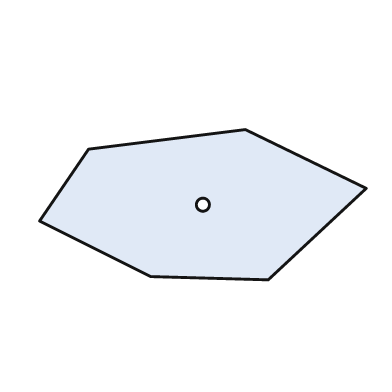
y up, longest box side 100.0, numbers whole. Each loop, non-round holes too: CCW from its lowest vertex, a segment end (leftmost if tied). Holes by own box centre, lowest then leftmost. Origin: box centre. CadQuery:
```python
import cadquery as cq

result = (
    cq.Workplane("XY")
    .moveTo(20.0, -23.0)
    .lineTo(50.0, 5.0)
    .lineTo(13.0, 23.0)
    .lineTo(-35.0, 17.0)
    .lineTo(-50.0, -5.0)
    .lineTo(-16.0, -22.0)
    .close()
    .moveTo(0.0, 0.0)
    .circle(2.0)
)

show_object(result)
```